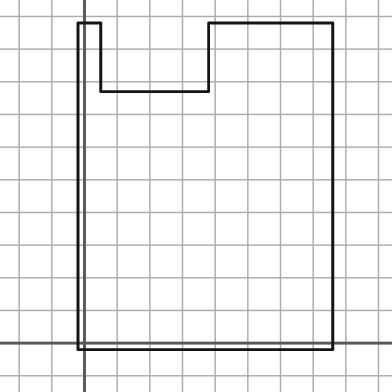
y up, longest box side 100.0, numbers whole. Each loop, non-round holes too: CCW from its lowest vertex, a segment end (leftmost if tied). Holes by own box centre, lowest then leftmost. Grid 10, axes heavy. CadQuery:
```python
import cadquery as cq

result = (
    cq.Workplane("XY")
    .moveTo(-2.0, -2.0)
    .lineTo(76.0, -2.0)
    .lineTo(76.0, 98.0)
    .lineTo(38.0, 98.0)
    .lineTo(38.0, 77.0)
    .lineTo(5.0, 77.0)
    .lineTo(5.0, 98.0)
    .lineTo(-2.0, 98.0)
    .close()
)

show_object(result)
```